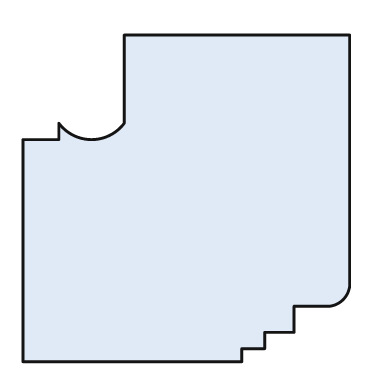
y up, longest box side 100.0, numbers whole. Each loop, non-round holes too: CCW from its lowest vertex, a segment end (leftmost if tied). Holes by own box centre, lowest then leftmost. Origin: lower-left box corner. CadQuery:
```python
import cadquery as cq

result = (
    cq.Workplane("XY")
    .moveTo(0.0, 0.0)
    .lineTo(67.0, 0.0)
    .lineTo(67.0, 4.0)
    .lineTo(74.0, 4.0)
    .lineTo(74.0, 9.0)
    .lineTo(83.0, 9.0)
    .lineTo(83.0, 17.0)
    .lineTo(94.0, 17.0)
    .threePointArc((98.0, 19.0), (100.0, 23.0))
    .lineTo(100.0, 100.0)
    .lineTo(31.0, 100.0)
    .lineTo(31.0, 73.0)
    .threePointArc((21.0, 68.0), (11.0, 73.0))
    .lineTo(11.0, 68.0)
    .lineTo(0.0, 68.0)
    .close()
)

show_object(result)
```